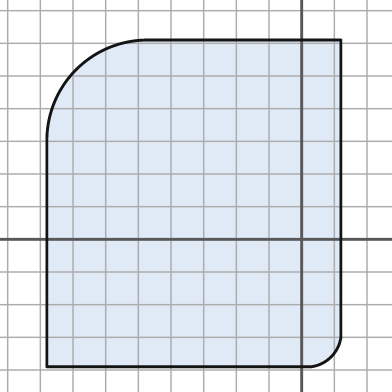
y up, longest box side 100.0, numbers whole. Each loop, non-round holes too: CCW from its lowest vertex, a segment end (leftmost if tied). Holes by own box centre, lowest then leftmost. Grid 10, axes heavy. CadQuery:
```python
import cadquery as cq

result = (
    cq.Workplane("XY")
    .moveTo(-78.0, -39.0)
    .lineTo(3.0, -39.0)
    .threePointArc((9.0, -36.0), (12.0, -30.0))
    .lineTo(12.0, 61.0)
    .lineTo(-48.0, 61.0)
    .threePointArc((-69.0, 52.0), (-78.0, 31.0))
    .close()
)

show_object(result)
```